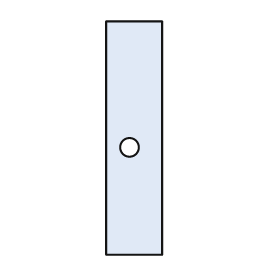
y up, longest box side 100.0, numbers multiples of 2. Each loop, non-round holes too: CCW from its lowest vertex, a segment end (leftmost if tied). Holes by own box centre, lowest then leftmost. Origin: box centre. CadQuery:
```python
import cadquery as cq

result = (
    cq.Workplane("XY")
    .moveTo(-12.0, -50.0)
    .lineTo(12.0, -50.0)
    .lineTo(12.0, 50.0)
    .lineTo(-12.0, 50.0)
    .close()
    .moveTo(-2.0, -4.0)
    .circle(4.0)
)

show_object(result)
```